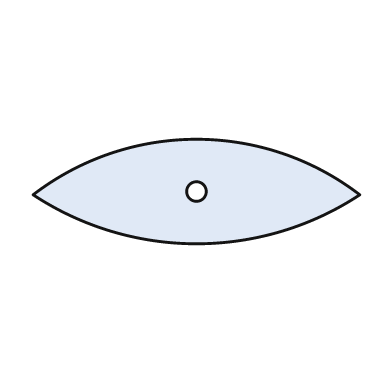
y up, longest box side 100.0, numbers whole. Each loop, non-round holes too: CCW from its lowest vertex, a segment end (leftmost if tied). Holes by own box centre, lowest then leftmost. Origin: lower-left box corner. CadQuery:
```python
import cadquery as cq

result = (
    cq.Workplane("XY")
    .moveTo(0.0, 15.0)
    .threePointArc((50.0, 0.0), (100.0, 15.0))
    .threePointArc((50.0, 32.0), (0.0, 15.0))
    .close()
    .moveTo(50.0, 16.0)
    .circle(3.0)
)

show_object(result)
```